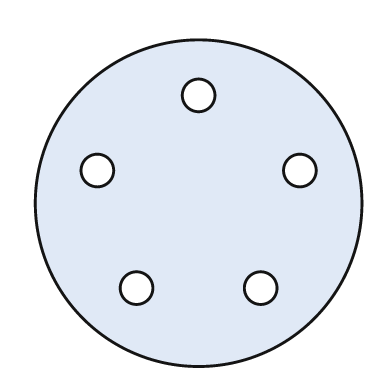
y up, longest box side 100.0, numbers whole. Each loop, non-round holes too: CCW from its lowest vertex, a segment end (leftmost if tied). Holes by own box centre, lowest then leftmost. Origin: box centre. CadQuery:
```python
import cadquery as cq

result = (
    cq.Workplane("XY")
    .moveTo(0.0, 0.0)
    .circle(50.0)
    .moveTo(-19.0, -26.0)
    .circle(5.0)
    .moveTo(19.0, -26.0)
    .circle(5.0)
    .moveTo(-31.0, 10.0)
    .circle(5.0)
    .moveTo(31.0, 10.0)
    .circle(5.0)
    .moveTo(0.0, 33.0)
    .circle(5.0)
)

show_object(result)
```